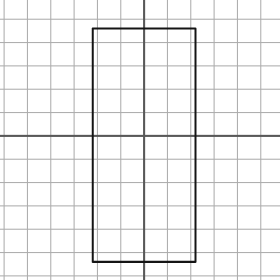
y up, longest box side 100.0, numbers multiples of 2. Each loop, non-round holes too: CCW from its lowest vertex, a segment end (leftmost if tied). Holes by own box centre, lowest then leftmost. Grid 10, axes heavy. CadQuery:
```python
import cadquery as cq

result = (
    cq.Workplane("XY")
    .moveTo(-22.0, -54.0)
    .lineTo(22.0, -54.0)
    .lineTo(22.0, 46.0)
    .lineTo(-22.0, 46.0)
    .close()
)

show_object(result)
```